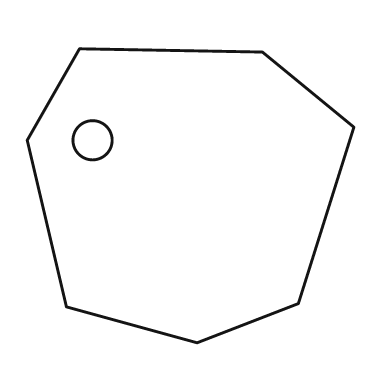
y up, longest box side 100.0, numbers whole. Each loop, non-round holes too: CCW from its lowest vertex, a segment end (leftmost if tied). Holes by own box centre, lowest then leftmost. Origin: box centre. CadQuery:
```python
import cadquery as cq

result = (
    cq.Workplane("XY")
    .moveTo(2.0, -45.0)
    .lineTo(33.0, -33.0)
    .lineTo(50.0, 21.0)
    .lineTo(22.0, 44.0)
    .lineTo(-34.0, 45.0)
    .lineTo(-50.0, 17.0)
    .lineTo(-38.0, -34.0)
    .close()
    .moveTo(-30.0, 17.0)
    .circle(6.0)
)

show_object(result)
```